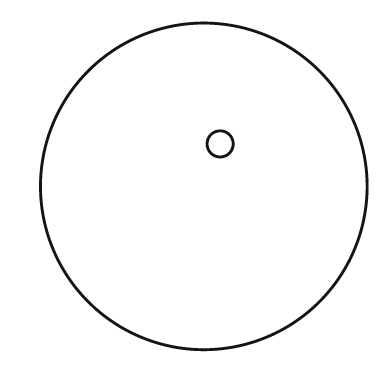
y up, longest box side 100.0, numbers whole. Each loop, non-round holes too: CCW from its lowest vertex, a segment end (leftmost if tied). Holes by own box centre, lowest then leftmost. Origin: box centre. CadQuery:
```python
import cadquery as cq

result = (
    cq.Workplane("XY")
    .moveTo(0.0, 0.0)
    .circle(50.0)
    .moveTo(5.0, 13.0)
    .circle(4.0)
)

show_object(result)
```